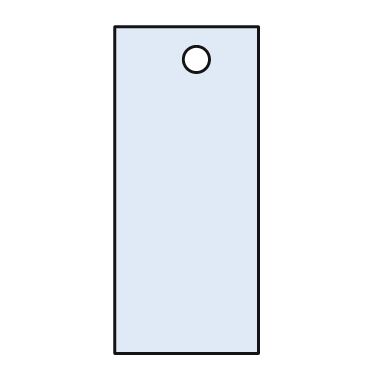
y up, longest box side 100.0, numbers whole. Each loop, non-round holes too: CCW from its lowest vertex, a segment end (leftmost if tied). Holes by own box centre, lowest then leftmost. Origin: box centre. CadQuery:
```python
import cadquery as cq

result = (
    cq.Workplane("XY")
    .moveTo(-22.0, -50.0)
    .lineTo(22.0, -50.0)
    .lineTo(22.0, 50.0)
    .lineTo(-22.0, 50.0)
    .close()
    .moveTo(3.0, 40.0)
    .circle(4.0)
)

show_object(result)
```